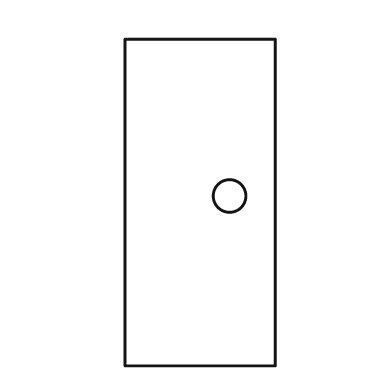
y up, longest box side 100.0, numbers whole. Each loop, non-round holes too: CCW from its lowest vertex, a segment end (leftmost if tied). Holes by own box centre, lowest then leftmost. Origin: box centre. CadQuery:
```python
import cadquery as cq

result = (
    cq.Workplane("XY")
    .moveTo(-23.0, -50.0)
    .lineTo(23.0, -50.0)
    .lineTo(23.0, 50.0)
    .lineTo(-23.0, 50.0)
    .close()
    .moveTo(9.0, 2.0)
    .circle(5.0)
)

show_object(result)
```